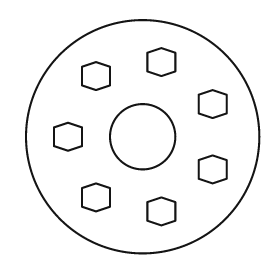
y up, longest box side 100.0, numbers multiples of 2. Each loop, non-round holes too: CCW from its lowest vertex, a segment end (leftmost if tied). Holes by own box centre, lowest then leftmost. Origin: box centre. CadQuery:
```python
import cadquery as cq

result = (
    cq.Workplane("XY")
    .moveTo(0.0, 0.0)
    .circle(50.0)
    .moveTo(8.0, -38.0)
    .lineTo(14.0, -36.0)
    .lineTo(14.0, -28.0)
    .lineTo(8.0, -26.0)
    .lineTo(2.0, -28.0)
    .lineTo(2.0, -36.0)
    .close()
    .moveTo(-20.0, -32.0)
    .lineTo(-14.0, -30.0)
    .lineTo(-14.0, -22.0)
    .lineTo(-20.0, -20.0)
    .lineTo(-26.0, -22.0)
    .lineTo(-26.0, -30.0)
    .close()
    .moveTo(30.0, -20.0)
    .lineTo(36.0, -18.0)
    .lineTo(36.0, -10.0)
    .lineTo(30.0, -8.0)
    .lineTo(24.0, -10.0)
    .lineTo(24.0, -18.0)
    .close()
    .moveTo(-32.0, -6.0)
    .lineTo(-26.0, -4.0)
    .lineTo(-26.0, 4.0)
    .lineTo(-32.0, 6.0)
    .lineTo(-38.0, 4.0)
    .lineTo(-38.0, -4.0)
    .close()
    .moveTo(0.0, 0.0)
    .circle(14.0)
    .moveTo(30.0, 8.0)
    .lineTo(36.0, 10.0)
    .lineTo(36.0, 18.0)
    .lineTo(30.0, 20.0)
    .lineTo(24.0, 18.0)
    .lineTo(24.0, 10.0)
    .close()
    .moveTo(-20.0, 20.0)
    .lineTo(-14.0, 22.0)
    .lineTo(-14.0, 30.0)
    .lineTo(-20.0, 32.0)
    .lineTo(-26.0, 30.0)
    .lineTo(-26.0, 22.0)
    .close()
    .moveTo(8.0, 26.0)
    .lineTo(14.0, 28.0)
    .lineTo(14.0, 36.0)
    .lineTo(8.0, 38.0)
    .lineTo(2.0, 36.0)
    .lineTo(2.0, 28.0)
    .close()
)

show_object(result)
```